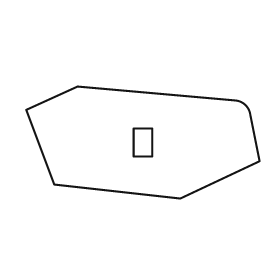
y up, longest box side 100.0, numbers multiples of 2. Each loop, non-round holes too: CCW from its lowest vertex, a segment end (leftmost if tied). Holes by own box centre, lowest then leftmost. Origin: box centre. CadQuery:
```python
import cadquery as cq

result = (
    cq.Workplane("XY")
    .moveTo(16.0, -24.0)
    .lineTo(50.0, -8.0)
    .lineTo(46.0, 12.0)
    .threePointArc((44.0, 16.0), (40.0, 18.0))
    .lineTo(-28.0, 24.0)
    .lineTo(-50.0, 14.0)
    .lineTo(-38.0, -18.0)
    .close()
    .moveTo(-4.0, -6.0)
    .lineTo(4.0, -6.0)
    .lineTo(4.0, 6.0)
    .lineTo(-4.0, 6.0)
    .close()
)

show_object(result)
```